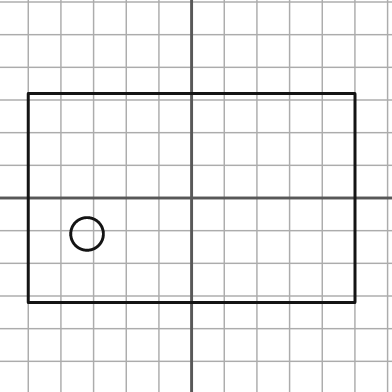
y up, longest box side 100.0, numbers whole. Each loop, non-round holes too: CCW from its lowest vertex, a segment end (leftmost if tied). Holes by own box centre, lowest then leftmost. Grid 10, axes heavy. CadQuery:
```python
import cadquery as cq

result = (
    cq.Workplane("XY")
    .moveTo(-50.0, -32.0)
    .lineTo(50.0, -32.0)
    .lineTo(50.0, 32.0)
    .lineTo(-50.0, 32.0)
    .close()
    .moveTo(-32.0, -11.0)
    .circle(5.0)
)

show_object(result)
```